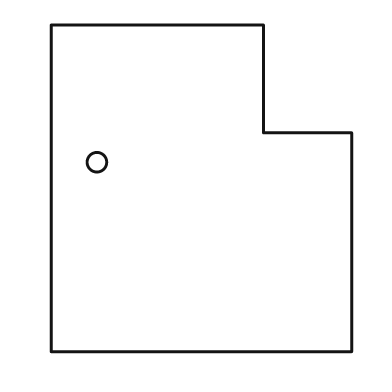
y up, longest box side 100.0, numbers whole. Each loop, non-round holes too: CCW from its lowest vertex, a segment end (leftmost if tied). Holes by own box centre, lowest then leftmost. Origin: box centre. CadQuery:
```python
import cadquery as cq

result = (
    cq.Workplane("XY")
    .moveTo(-46.0, -50.0)
    .lineTo(46.0, -50.0)
    .lineTo(46.0, 17.0)
    .lineTo(19.0, 17.0)
    .lineTo(19.0, 50.0)
    .lineTo(-46.0, 50.0)
    .close()
    .moveTo(-32.0, 8.0)
    .circle(3.0)
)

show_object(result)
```